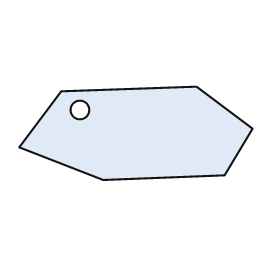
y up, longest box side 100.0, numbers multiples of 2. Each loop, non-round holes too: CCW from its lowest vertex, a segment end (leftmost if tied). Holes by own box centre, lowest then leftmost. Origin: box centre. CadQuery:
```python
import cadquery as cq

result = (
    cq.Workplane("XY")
    .moveTo(-14.0, -20.0)
    .lineTo(38.0, -18.0)
    .lineTo(50.0, 2.0)
    .lineTo(26.0, 20.0)
    .lineTo(-32.0, 18.0)
    .lineTo(-50.0, -6.0)
    .close()
    .moveTo(-24.0, 10.0)
    .circle(4.0)
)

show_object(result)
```